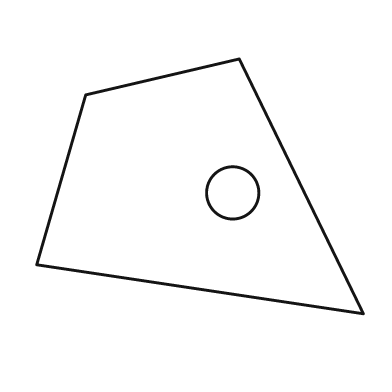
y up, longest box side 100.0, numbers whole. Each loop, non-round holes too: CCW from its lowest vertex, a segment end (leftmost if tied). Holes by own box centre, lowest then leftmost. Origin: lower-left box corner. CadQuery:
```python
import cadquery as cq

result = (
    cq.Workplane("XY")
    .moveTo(100.0, 0.0)
    .lineTo(62.0, 78.0)
    .lineTo(15.0, 67.0)
    .lineTo(0.0, 15.0)
    .close()
    .moveTo(60.0, 37.0)
    .circle(8.0)
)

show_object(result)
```